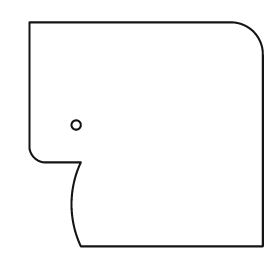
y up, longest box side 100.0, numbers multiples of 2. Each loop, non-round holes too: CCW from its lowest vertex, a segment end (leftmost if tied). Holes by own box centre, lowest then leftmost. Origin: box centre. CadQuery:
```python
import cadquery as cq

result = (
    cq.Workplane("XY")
    .moveTo(-28.0, -48.0)
    .lineTo(50.0, -48.0)
    .lineTo(50.0, 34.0)
    .threePointArc((46.0, 44.0), (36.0, 48.0))
    .lineTo(-50.0, 48.0)
    .lineTo(-50.0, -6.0)
    .threePointArc((-48.0, -10.0), (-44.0, -12.0))
    .lineTo(-28.0, -12.0)
    .threePointArc((-32.0, -30.0), (-28.0, -48.0))
    .close()
    .moveTo(-30.0, 4.0)
    .circle(2.0)
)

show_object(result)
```